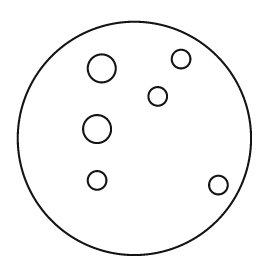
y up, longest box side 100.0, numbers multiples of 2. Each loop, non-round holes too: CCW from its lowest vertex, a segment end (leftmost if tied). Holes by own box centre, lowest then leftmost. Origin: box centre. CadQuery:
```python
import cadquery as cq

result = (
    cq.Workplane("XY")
    .moveTo(0.0, 0.0)
    .circle(50.0)
    .moveTo(36.0, -20.0)
    .circle(4.0)
    .moveTo(-16.0, -18.0)
    .circle(4.0)
    .moveTo(-16.0, 4.0)
    .circle(6.0)
    .moveTo(10.0, 18.0)
    .circle(4.0)
    .moveTo(-14.0, 30.0)
    .circle(6.0)
    .moveTo(20.0, 34.0)
    .circle(4.0)
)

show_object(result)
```